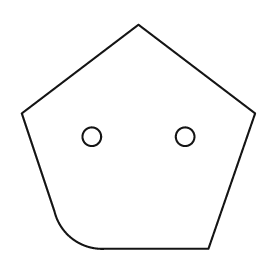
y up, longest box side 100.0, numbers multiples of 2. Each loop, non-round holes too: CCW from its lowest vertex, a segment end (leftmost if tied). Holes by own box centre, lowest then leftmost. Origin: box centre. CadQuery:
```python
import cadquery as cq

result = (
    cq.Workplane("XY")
    .moveTo(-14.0, -48.0)
    .lineTo(30.0, -48.0)
    .lineTo(50.0, 10.0)
    .lineTo(0.0, 48.0)
    .lineTo(-50.0, 10.0)
    .lineTo(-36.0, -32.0)
    .threePointArc((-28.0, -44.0), (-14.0, -48.0))
    .close()
    .moveTo(-20.0, 0.0)
    .circle(4.0)
    .moveTo(20.0, 0.0)
    .circle(4.0)
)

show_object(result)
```